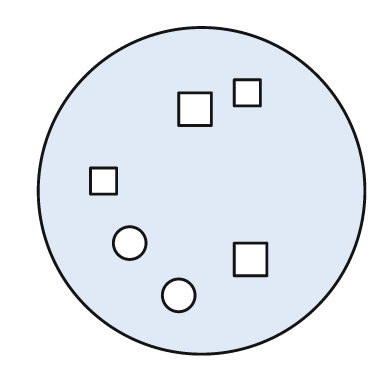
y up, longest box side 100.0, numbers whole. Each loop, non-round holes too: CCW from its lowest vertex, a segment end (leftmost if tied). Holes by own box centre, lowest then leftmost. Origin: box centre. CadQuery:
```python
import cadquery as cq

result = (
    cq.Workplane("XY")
    .moveTo(0.0, 0.0)
    .circle(50.0)
    .moveTo(-7.0, -32.0)
    .circle(5.0)
    .moveTo(10.0, -26.0)
    .lineTo(20.0, -26.0)
    .lineTo(20.0, -16.0)
    .lineTo(10.0, -16.0)
    .close()
    .moveTo(-22.0, -16.0)
    .circle(5.0)
    .moveTo(-34.0, -1.0)
    .lineTo(-26.0, -1.0)
    .lineTo(-26.0, 7.0)
    .lineTo(-34.0, 7.0)
    .close()
    .moveTo(-7.0, 20.0)
    .lineTo(3.0, 20.0)
    .lineTo(3.0, 30.0)
    .lineTo(-7.0, 30.0)
    .close()
    .moveTo(10.0, 26.0)
    .lineTo(18.0, 26.0)
    .lineTo(18.0, 34.0)
    .lineTo(10.0, 34.0)
    .close()
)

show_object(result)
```